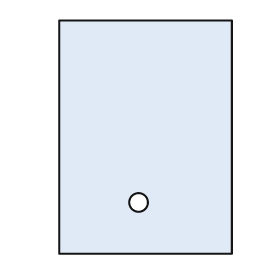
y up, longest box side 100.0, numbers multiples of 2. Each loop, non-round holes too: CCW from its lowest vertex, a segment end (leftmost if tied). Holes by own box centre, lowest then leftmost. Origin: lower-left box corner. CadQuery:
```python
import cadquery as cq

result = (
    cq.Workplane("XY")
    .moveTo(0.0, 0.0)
    .lineTo(74.0, 0.0)
    .lineTo(74.0, 100.0)
    .lineTo(0.0, 100.0)
    .close()
    .moveTo(34.0, 22.0)
    .circle(4.0)
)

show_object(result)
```